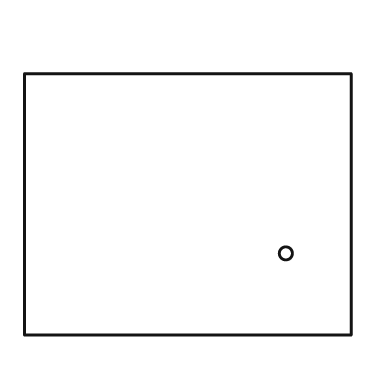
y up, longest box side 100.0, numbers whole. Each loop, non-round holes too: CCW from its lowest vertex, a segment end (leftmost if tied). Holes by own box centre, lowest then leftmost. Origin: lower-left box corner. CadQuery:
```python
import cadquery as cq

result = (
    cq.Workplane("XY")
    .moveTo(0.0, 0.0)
    .lineTo(100.0, 0.0)
    .lineTo(100.0, 80.0)
    .lineTo(0.0, 80.0)
    .close()
    .moveTo(80.0, 25.0)
    .circle(2.0)
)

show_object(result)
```